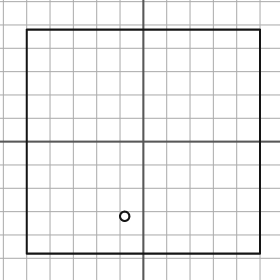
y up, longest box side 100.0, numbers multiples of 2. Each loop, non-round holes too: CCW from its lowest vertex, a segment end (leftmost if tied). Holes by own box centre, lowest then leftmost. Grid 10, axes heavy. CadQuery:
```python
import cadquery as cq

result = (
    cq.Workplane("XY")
    .moveTo(-50.0, -48.0)
    .lineTo(50.0, -48.0)
    .lineTo(50.0, 48.0)
    .lineTo(-50.0, 48.0)
    .close()
    .moveTo(-8.0, -32.0)
    .circle(2.0)
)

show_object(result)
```